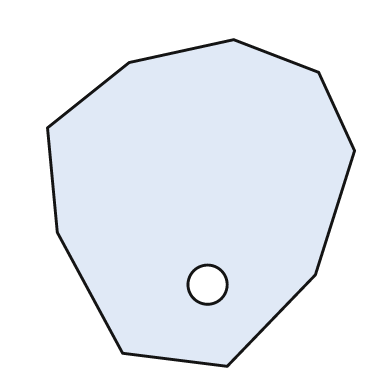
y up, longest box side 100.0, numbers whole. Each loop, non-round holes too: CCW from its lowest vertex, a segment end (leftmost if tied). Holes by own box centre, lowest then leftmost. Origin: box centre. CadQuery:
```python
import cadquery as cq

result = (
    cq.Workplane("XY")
    .moveTo(8.0, -50.0)
    .lineTo(35.0, -22.0)
    .lineTo(47.0, 16.0)
    .lineTo(36.0, 40.0)
    .lineTo(10.0, 50.0)
    .lineTo(-22.0, 43.0)
    .lineTo(-47.0, 23.0)
    .lineTo(-44.0, -9.0)
    .lineTo(-24.0, -46.0)
    .close()
    .moveTo(2.0, -25.0)
    .circle(6.0)
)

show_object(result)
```